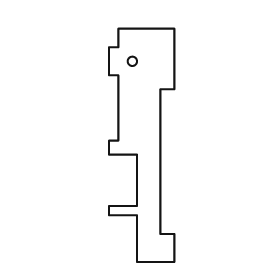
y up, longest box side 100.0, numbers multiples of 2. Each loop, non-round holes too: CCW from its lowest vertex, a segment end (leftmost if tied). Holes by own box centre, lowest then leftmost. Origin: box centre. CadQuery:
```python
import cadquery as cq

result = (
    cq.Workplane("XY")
    .moveTo(-2.0, -50.0)
    .lineTo(14.0, -50.0)
    .lineTo(14.0, -38.0)
    .lineTo(8.0, -38.0)
    .lineTo(8.0, 24.0)
    .lineTo(14.0, 24.0)
    .lineTo(14.0, 50.0)
    .lineTo(-10.0, 50.0)
    .lineTo(-10.0, 42.0)
    .lineTo(-14.0, 42.0)
    .lineTo(-14.0, 30.0)
    .lineTo(-10.0, 30.0)
    .lineTo(-10.0, 2.0)
    .lineTo(-14.0, 2.0)
    .lineTo(-14.0, -4.0)
    .lineTo(-2.0, -4.0)
    .lineTo(-2.0, -26.0)
    .lineTo(-14.0, -26.0)
    .lineTo(-14.0, -30.0)
    .lineTo(-2.0, -30.0)
    .close()
    .moveTo(-4.0, 36.0)
    .circle(2.0)
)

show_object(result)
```